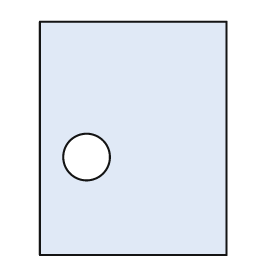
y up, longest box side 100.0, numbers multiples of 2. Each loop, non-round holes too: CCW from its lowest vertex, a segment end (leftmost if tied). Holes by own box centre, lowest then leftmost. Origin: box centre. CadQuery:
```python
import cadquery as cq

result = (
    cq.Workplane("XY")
    .moveTo(-40.0, -50.0)
    .lineTo(40.0, -50.0)
    .lineTo(40.0, 50.0)
    .lineTo(-40.0, 50.0)
    .close()
    .moveTo(-20.0, -8.0)
    .circle(10.0)
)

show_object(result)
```